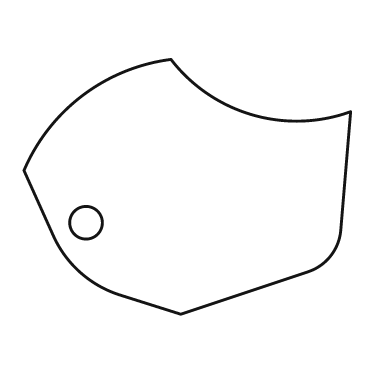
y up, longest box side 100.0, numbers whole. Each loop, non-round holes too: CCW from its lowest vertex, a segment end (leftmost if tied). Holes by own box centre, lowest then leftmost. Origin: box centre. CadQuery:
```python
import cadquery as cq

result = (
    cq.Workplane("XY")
    .moveTo(-2.0, -39.0)
    .lineTo(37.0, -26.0)
    .threePointArc((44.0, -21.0), (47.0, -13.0))
    .lineTo(50.0, 23.0)
    .threePointArc((20.0, 22.0), (-5.0, 39.0))
    .threePointArc((-32.0, 28.0), (-50.0, 5.0))
    .lineTo(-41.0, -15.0)
    .threePointArc((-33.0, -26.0), (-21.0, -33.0))
    .close()
    .moveTo(-31.0, -11.0)
    .circle(5.0)
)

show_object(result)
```